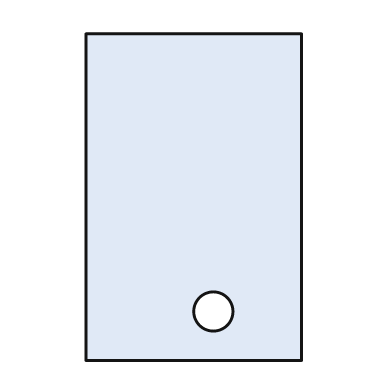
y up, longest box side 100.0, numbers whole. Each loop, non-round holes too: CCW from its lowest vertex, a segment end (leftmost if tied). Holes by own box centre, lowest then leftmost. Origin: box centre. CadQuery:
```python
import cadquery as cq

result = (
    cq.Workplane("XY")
    .moveTo(-33.0, -50.0)
    .lineTo(33.0, -50.0)
    .lineTo(33.0, 50.0)
    .lineTo(-33.0, 50.0)
    .close()
    .moveTo(6.0, -35.0)
    .circle(6.0)
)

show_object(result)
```